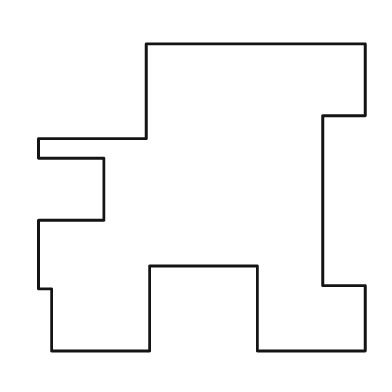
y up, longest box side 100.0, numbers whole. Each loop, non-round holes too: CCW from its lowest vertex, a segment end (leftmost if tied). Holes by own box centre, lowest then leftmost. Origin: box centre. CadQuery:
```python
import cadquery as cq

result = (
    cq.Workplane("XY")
    .moveTo(-46.0, -47.0)
    .lineTo(-16.0, -47.0)
    .lineTo(-16.0, -21.0)
    .lineTo(17.0, -21.0)
    .lineTo(17.0, -47.0)
    .lineTo(50.0, -47.0)
    .lineTo(50.0, -27.0)
    .lineTo(37.0, -27.0)
    .lineTo(37.0, 25.0)
    .lineTo(50.0, 25.0)
    .lineTo(50.0, 47.0)
    .lineTo(-17.0, 47.0)
    .lineTo(-17.0, 18.0)
    .lineTo(-50.0, 18.0)
    .lineTo(-50.0, 12.0)
    .lineTo(-30.0, 12.0)
    .lineTo(-30.0, -7.0)
    .lineTo(-50.0, -7.0)
    .lineTo(-50.0, -28.0)
    .lineTo(-46.0, -28.0)
    .close()
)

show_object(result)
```